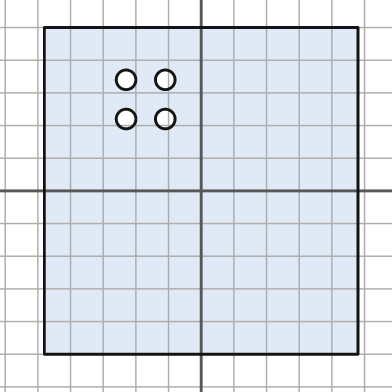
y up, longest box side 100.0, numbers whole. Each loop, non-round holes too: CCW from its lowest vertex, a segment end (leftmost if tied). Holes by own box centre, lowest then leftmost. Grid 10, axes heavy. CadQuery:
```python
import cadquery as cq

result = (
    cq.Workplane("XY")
    .moveTo(-48.0, -50.0)
    .lineTo(48.0, -50.0)
    .lineTo(48.0, 50.0)
    .lineTo(-48.0, 50.0)
    .close()
    .moveTo(-23.0, 22.0)
    .circle(3.0)
    .moveTo(-11.0, 22.0)
    .circle(3.0)
    .moveTo(-23.0, 34.0)
    .circle(3.0)
    .moveTo(-11.0, 34.0)
    .circle(3.0)
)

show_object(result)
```